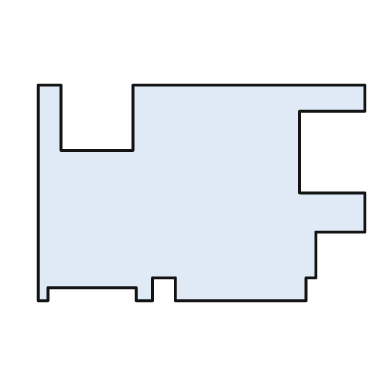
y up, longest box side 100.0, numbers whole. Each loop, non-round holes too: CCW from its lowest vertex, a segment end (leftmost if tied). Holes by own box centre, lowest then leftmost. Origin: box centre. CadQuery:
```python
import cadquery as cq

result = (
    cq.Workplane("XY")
    .moveTo(-50.0, -33.0)
    .lineTo(-47.0, -33.0)
    .lineTo(-47.0, -29.0)
    .lineTo(-20.0, -29.0)
    .lineTo(-20.0, -33.0)
    .lineTo(-15.0, -33.0)
    .lineTo(-15.0, -26.0)
    .lineTo(-8.0, -26.0)
    .lineTo(-8.0, -33.0)
    .lineTo(32.0, -33.0)
    .lineTo(32.0, -26.0)
    .lineTo(35.0, -26.0)
    .lineTo(35.0, -12.0)
    .lineTo(50.0, -12.0)
    .lineTo(50.0, 0.0)
    .lineTo(30.0, 0.0)
    .lineTo(30.0, 25.0)
    .lineTo(50.0, 25.0)
    .lineTo(50.0, 33.0)
    .lineTo(-21.0, 33.0)
    .lineTo(-21.0, 13.0)
    .lineTo(-43.0, 13.0)
    .lineTo(-43.0, 33.0)
    .lineTo(-50.0, 33.0)
    .close()
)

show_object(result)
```